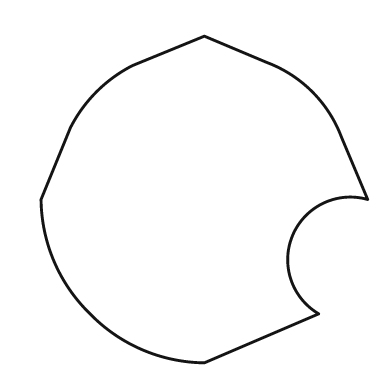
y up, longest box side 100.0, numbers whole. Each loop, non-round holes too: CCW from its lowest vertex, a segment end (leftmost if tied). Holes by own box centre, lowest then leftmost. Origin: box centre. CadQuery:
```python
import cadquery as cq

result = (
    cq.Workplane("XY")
    .moveTo(0.0, -50.0)
    .lineTo(35.0, -35.0)
    .threePointArc((27.0, -11.0), (50.0, 0.0))
    .lineTo(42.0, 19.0)
    .threePointArc((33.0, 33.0), (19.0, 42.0))
    .lineTo(0.0, 50.0)
    .lineTo(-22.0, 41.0)
    .threePointArc((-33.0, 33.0), (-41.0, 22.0))
    .lineTo(-50.0, 0.0)
    .threePointArc((-46.0, -19.0), (-35.0, -35.0))
    .threePointArc((-19.0, -46.0), (0.0, -50.0))
    .close()
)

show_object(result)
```